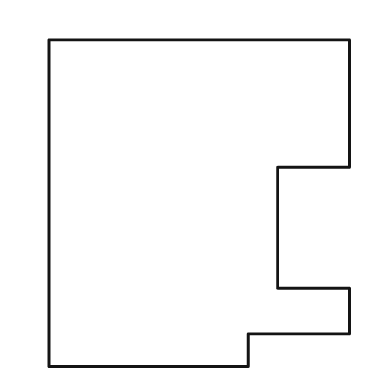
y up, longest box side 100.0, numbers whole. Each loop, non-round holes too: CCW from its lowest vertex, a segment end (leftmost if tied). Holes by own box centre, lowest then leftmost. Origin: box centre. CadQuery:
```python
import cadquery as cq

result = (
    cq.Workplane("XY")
    .moveTo(-46.0, -50.0)
    .lineTo(15.0, -50.0)
    .lineTo(15.0, -40.0)
    .lineTo(46.0, -40.0)
    .lineTo(46.0, -26.0)
    .lineTo(24.0, -26.0)
    .lineTo(24.0, 11.0)
    .lineTo(46.0, 11.0)
    .lineTo(46.0, 50.0)
    .lineTo(-46.0, 50.0)
    .close()
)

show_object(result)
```